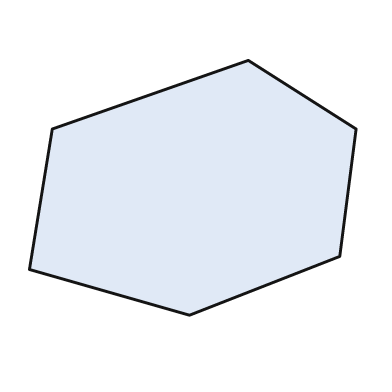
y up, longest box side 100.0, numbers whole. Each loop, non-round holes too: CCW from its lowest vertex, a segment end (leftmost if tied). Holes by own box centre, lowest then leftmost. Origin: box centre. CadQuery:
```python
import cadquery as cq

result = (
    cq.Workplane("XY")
    .moveTo(-1.0, -39.0)
    .lineTo(45.0, -21.0)
    .lineTo(50.0, 18.0)
    .lineTo(17.0, 39.0)
    .lineTo(-43.0, 18.0)
    .lineTo(-50.0, -25.0)
    .close()
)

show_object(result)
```